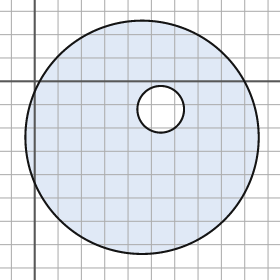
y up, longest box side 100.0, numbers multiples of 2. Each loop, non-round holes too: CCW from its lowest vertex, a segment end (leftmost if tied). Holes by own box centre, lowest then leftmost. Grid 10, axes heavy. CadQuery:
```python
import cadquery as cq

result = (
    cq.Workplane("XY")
    .moveTo(46.0, -24.0)
    .circle(50.0)
    .moveTo(54.0, -12.0)
    .circle(10.0)
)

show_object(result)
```